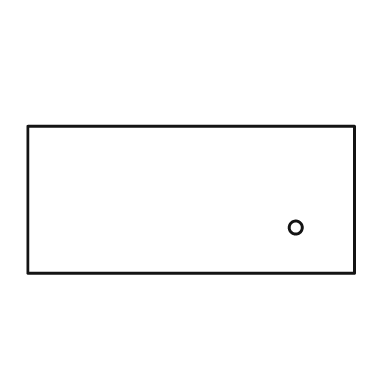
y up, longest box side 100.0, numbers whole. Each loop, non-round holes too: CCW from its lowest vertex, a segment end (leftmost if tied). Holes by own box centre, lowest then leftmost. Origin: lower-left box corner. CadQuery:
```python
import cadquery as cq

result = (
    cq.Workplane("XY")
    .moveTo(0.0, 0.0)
    .lineTo(100.0, 0.0)
    .lineTo(100.0, 45.0)
    .lineTo(0.0, 45.0)
    .close()
    .moveTo(82.0, 14.0)
    .circle(2.0)
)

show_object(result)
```